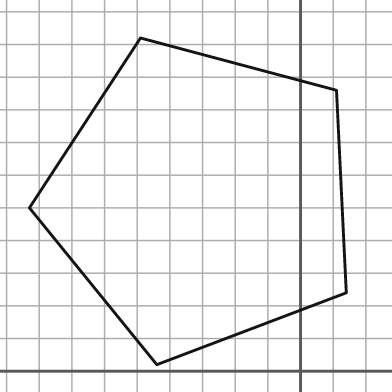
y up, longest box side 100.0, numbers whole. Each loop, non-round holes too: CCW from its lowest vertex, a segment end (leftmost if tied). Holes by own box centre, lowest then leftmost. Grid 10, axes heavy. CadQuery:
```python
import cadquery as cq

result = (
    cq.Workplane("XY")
    .moveTo(-44.0, 2.0)
    .lineTo(14.0, 24.0)
    .lineTo(11.0, 86.0)
    .lineTo(-49.0, 102.0)
    .lineTo(-83.0, 50.0)
    .close()
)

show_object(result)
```